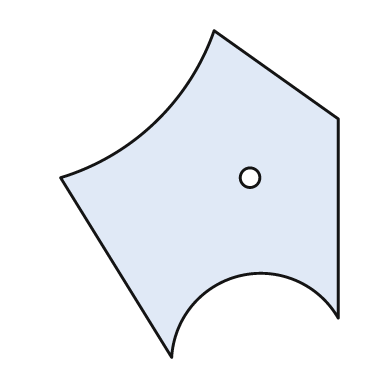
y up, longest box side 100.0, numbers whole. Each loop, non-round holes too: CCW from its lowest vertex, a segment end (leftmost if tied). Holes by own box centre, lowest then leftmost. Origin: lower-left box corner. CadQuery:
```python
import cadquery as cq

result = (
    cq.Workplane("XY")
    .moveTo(34.0, 0.0)
    .threePointArc((55.0, 25.0), (85.0, 12.0))
    .lineTo(85.0, 73.0)
    .lineTo(47.0, 100.0)
    .threePointArc((29.0, 72.0), (0.0, 55.0))
    .close()
    .moveTo(58.0, 55.0)
    .circle(3.0)
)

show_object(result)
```